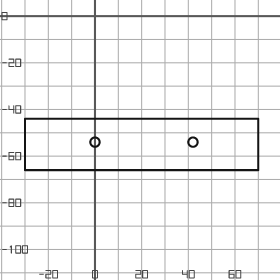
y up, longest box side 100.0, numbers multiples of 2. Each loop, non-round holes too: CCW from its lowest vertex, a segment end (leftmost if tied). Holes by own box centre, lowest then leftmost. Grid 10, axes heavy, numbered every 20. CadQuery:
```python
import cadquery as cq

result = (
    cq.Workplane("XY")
    .moveTo(-30.0, -66.0)
    .lineTo(70.0, -66.0)
    .lineTo(70.0, -44.0)
    .lineTo(-30.0, -44.0)
    .close()
    .moveTo(0.0, -54.0)
    .circle(2.0)
    .moveTo(42.0, -54.0)
    .circle(2.0)
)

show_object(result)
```